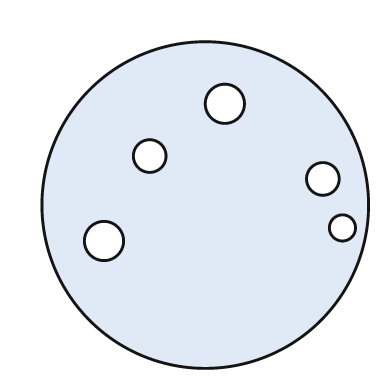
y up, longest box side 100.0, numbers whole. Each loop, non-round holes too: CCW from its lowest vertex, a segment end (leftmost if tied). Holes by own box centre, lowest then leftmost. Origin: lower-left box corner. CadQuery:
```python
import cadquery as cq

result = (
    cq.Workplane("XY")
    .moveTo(50.0, 50.0)
    .circle(50.0)
    .moveTo(19.0, 39.0)
    .circle(6.0)
    .moveTo(92.0, 43.0)
    .circle(4.0)
    .moveTo(86.0, 58.0)
    .circle(5.0)
    .moveTo(33.0, 65.0)
    .circle(5.0)
    .moveTo(56.0, 81.0)
    .circle(6.0)
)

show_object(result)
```